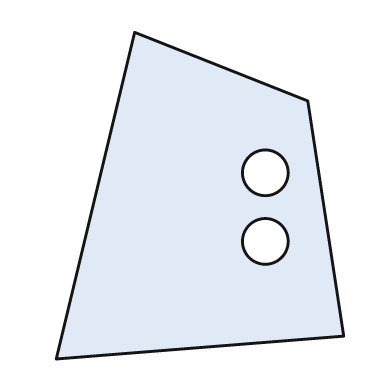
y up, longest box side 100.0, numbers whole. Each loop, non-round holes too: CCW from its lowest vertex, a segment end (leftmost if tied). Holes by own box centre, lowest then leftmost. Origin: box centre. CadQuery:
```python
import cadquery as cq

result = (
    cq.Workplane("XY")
    .moveTo(-44.0, -50.0)
    .lineTo(44.0, -43.0)
    .lineTo(33.0, 29.0)
    .lineTo(-20.0, 50.0)
    .close()
    .moveTo(20.0, -14.0)
    .circle(7.0)
    .moveTo(20.0, 7.0)
    .circle(7.0)
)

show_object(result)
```